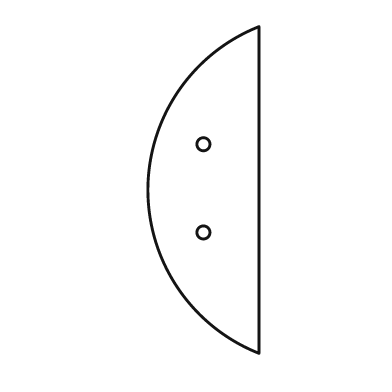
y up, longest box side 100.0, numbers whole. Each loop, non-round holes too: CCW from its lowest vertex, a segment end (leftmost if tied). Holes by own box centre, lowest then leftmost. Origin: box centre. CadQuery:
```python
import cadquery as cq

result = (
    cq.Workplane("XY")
    .moveTo(17.0, -50.0)
    .lineTo(17.0, 50.0)
    .threePointArc((-17.0, 0.0), (17.0, -50.0))
    .close()
    .moveTo(0.0, -13.0)
    .circle(2.0)
    .moveTo(0.0, 14.0)
    .circle(2.0)
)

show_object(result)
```